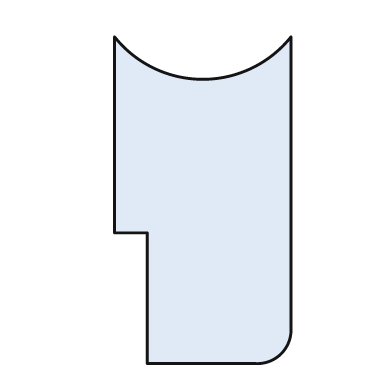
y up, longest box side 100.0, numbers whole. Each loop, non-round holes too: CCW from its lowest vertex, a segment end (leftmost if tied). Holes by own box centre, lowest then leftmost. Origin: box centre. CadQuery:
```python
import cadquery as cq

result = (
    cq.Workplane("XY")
    .moveTo(-17.0, -50.0)
    .lineTo(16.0, -50.0)
    .threePointArc((24.0, -47.0), (27.0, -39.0))
    .lineTo(27.0, 50.0)
    .threePointArc((0.0, 37.0), (-27.0, 50.0))
    .lineTo(-27.0, -10.0)
    .lineTo(-17.0, -10.0)
    .close()
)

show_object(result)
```